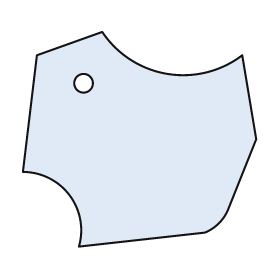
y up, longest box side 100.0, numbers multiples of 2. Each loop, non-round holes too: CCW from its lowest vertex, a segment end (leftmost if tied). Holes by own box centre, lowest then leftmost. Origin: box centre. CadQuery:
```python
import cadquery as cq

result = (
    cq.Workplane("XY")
    .moveTo(-26.0, -46.0)
    .lineTo(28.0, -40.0)
    .threePointArc((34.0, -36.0), (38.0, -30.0))
    .lineTo(50.0, 0.0)
    .lineTo(44.0, 36.0)
    .threePointArc((12.0, 28.0), (-16.0, 46.0))
    .lineTo(-44.0, 36.0)
    .lineTo(-50.0, -14.0)
    .threePointArc((-30.0, -24.0), (-26.0, -46.0))
    .close()
    .moveTo(-24.0, 24.0)
    .circle(4.0)
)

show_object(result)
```